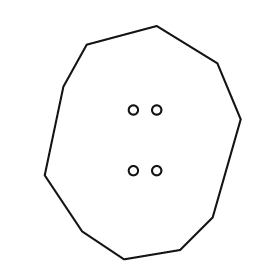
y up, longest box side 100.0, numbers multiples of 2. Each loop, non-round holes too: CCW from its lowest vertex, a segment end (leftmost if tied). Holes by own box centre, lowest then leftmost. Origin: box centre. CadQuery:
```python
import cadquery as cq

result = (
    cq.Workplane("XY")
    .moveTo(-8.0, -50.0)
    .lineTo(16.0, -46.0)
    .lineTo(30.0, -32.0)
    .lineTo(42.0, 10.0)
    .lineTo(32.0, 34.0)
    .lineTo(6.0, 50.0)
    .lineTo(-24.0, 42.0)
    .lineTo(-34.0, 24.0)
    .lineTo(-42.0, -14.0)
    .lineTo(-26.0, -38.0)
    .close()
    .moveTo(-4.0, -12.0)
    .circle(2.0)
    .moveTo(6.0, -12.0)
    .circle(2.0)
    .moveTo(-4.0, 14.0)
    .circle(2.0)
    .moveTo(6.0, 14.0)
    .circle(2.0)
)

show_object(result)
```